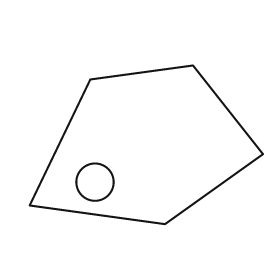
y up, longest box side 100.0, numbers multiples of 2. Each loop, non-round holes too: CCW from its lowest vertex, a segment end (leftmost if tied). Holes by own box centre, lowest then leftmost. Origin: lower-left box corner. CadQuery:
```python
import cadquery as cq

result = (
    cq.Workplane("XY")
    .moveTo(58.0, 0.0)
    .lineTo(100.0, 30.0)
    .lineTo(70.0, 68.0)
    .lineTo(26.0, 62.0)
    .lineTo(0.0, 8.0)
    .close()
    .moveTo(28.0, 18.0)
    .circle(8.0)
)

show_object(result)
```